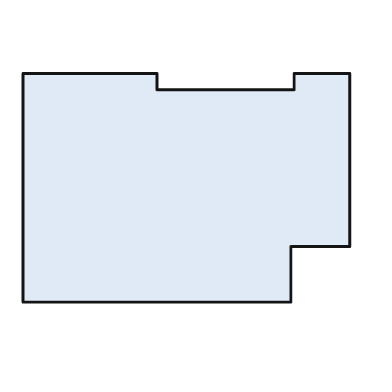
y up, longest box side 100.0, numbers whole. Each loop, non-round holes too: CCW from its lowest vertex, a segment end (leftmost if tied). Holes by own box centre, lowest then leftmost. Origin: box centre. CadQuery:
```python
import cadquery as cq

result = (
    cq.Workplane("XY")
    .moveTo(-50.0, -35.0)
    .lineTo(32.0, -35.0)
    .lineTo(32.0, -18.0)
    .lineTo(50.0, -18.0)
    .lineTo(50.0, 35.0)
    .lineTo(33.0, 35.0)
    .lineTo(33.0, 30.0)
    .lineTo(-9.0, 30.0)
    .lineTo(-9.0, 35.0)
    .lineTo(-50.0, 35.0)
    .close()
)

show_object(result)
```